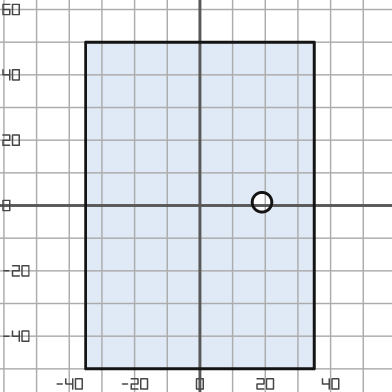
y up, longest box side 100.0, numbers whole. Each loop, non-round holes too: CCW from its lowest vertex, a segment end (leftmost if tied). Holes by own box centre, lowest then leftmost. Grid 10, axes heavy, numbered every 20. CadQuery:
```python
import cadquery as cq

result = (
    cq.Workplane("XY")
    .moveTo(-35.0, -50.0)
    .lineTo(35.0, -50.0)
    .lineTo(35.0, 50.0)
    .lineTo(-35.0, 50.0)
    .close()
    .moveTo(19.0, 1.0)
    .circle(3.0)
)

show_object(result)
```